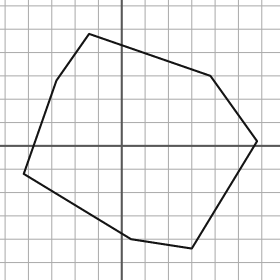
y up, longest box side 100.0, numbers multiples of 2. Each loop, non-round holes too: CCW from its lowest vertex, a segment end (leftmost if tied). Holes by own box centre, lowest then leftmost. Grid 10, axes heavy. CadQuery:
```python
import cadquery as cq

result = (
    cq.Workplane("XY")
    .moveTo(30.0, -44.0)
    .lineTo(58.0, 2.0)
    .lineTo(38.0, 30.0)
    .lineTo(-14.0, 48.0)
    .lineTo(-28.0, 28.0)
    .lineTo(-42.0, -12.0)
    .lineTo(4.0, -40.0)
    .close()
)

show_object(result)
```